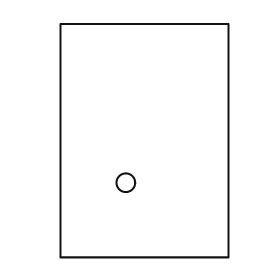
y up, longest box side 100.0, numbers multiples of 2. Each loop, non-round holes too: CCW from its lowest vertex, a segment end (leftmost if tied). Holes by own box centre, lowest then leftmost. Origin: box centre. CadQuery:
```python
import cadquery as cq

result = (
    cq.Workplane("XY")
    .moveTo(-36.0, -50.0)
    .lineTo(36.0, -50.0)
    .lineTo(36.0, 50.0)
    .lineTo(-36.0, 50.0)
    .close()
    .moveTo(-8.0, -18.0)
    .circle(4.0)
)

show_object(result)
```